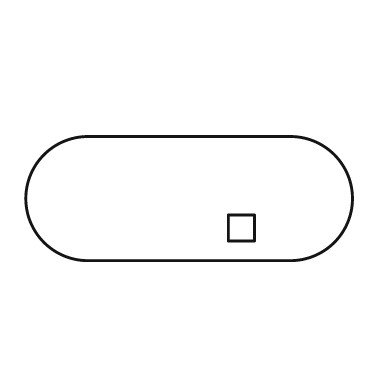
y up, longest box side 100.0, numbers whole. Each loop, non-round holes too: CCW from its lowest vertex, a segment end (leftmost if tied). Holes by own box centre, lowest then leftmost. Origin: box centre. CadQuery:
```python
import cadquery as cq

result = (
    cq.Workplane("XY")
    .moveTo(-31.0, -19.0)
    .lineTo(31.0, -19.0)
    .threePointArc((50.0, 0.0), (31.0, 19.0))
    .lineTo(-31.0, 19.0)
    .threePointArc((-50.0, 0.0), (-31.0, -19.0))
    .close()
    .moveTo(12.0, -13.0)
    .lineTo(20.0, -13.0)
    .lineTo(20.0, -5.0)
    .lineTo(12.0, -5.0)
    .close()
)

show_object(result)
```